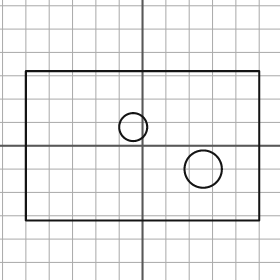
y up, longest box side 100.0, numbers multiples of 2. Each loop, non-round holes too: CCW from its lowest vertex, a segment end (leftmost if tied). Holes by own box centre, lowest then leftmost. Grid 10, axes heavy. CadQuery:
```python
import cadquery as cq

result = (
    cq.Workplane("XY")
    .moveTo(-50.0, -32.0)
    .lineTo(50.0, -32.0)
    .lineTo(50.0, 32.0)
    .lineTo(-50.0, 32.0)
    .close()
    .moveTo(26.0, -10.0)
    .circle(8.0)
    .moveTo(-4.0, 8.0)
    .circle(6.0)
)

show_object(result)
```